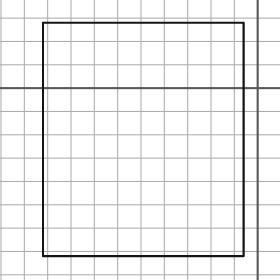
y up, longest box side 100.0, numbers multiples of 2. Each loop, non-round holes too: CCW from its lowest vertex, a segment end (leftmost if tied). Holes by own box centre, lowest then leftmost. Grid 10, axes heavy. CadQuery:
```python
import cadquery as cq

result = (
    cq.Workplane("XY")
    .moveTo(-92.0, -72.0)
    .lineTo(-6.0, -72.0)
    .lineTo(-6.0, 28.0)
    .lineTo(-92.0, 28.0)
    .close()
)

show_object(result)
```